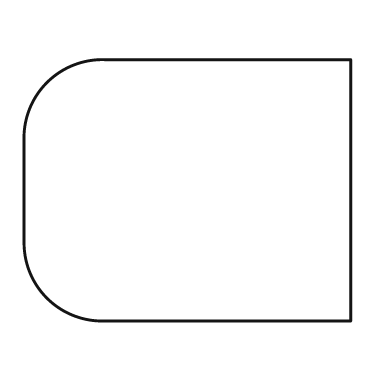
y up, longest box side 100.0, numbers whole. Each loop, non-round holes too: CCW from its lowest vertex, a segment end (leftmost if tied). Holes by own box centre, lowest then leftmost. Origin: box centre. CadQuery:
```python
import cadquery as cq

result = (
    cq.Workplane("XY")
    .moveTo(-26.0, -40.0)
    .lineTo(50.0, -40.0)
    .lineTo(50.0, 40.0)
    .lineTo(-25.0, 40.0)
    .threePointArc((-43.0, 33.0), (-50.0, 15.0))
    .lineTo(-50.0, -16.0)
    .threePointArc((-43.0, -33.0), (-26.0, -40.0))
    .close()
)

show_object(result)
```